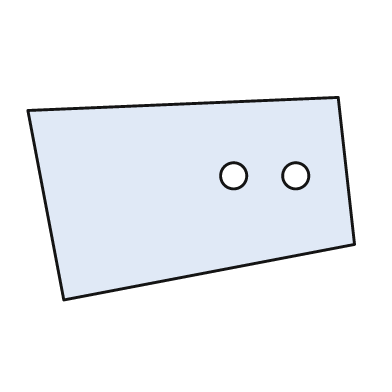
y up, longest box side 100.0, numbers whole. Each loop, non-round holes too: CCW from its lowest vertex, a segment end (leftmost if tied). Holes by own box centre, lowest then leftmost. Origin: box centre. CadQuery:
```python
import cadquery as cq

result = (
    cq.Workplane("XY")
    .moveTo(-39.0, -31.0)
    .lineTo(50.0, -14.0)
    .lineTo(45.0, 31.0)
    .lineTo(-50.0, 27.0)
    .close()
    .moveTo(13.0, 7.0)
    .circle(4.0)
    .moveTo(32.0, 7.0)
    .circle(4.0)
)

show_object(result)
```